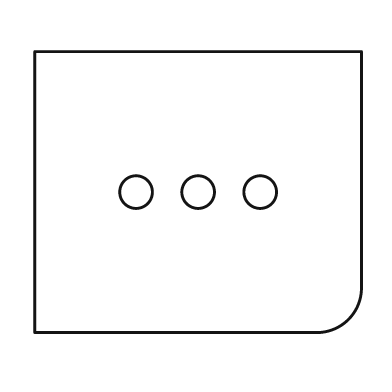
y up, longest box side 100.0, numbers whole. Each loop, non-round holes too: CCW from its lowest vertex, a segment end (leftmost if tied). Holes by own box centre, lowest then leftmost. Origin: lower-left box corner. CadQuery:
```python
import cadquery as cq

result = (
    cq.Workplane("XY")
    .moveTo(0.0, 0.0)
    .lineTo(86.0, 0.0)
    .threePointArc((96.0, 4.0), (100.0, 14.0))
    .lineTo(100.0, 86.0)
    .lineTo(0.0, 86.0)
    .close()
    .moveTo(31.0, 43.0)
    .circle(5.0)
    .moveTo(50.0, 43.0)
    .circle(5.0)
    .moveTo(69.0, 43.0)
    .circle(5.0)
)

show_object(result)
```